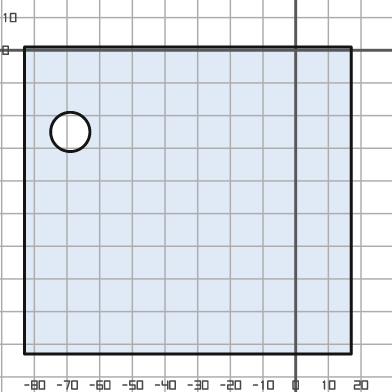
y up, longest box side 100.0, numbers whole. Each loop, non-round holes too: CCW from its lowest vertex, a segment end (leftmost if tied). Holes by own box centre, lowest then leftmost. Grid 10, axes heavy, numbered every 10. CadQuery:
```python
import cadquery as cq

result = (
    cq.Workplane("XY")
    .moveTo(-83.0, -93.0)
    .lineTo(17.0, -93.0)
    .lineTo(17.0, 1.0)
    .lineTo(-83.0, 1.0)
    .close()
    .moveTo(-69.0, -25.0)
    .circle(6.0)
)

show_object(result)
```